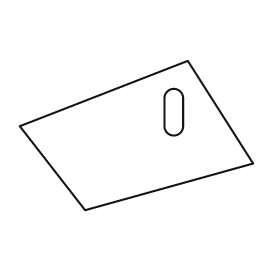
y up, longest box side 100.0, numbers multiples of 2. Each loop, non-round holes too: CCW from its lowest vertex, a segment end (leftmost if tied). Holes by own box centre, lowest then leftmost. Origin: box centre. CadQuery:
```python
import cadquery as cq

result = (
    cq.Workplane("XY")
    .moveTo(-22.0, -32.0)
    .lineTo(50.0, -12.0)
    .lineTo(22.0, 32.0)
    .lineTo(-50.0, 4.0)
    .close()
    .moveTo(12.0, 4.0)
    .threePointArc((16.0, 0.0), (20.0, 4.0))
    .lineTo(20.0, 16.0)
    .threePointArc((16.0, 20.0), (12.0, 16.0))
    .close()
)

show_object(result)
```